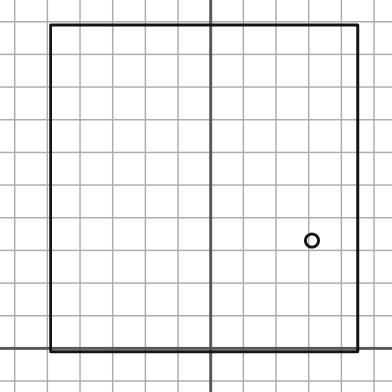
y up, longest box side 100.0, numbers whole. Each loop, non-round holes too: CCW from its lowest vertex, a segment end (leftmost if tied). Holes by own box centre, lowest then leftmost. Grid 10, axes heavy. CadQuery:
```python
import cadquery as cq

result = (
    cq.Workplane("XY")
    .moveTo(-49.0, -1.0)
    .lineTo(45.0, -1.0)
    .lineTo(45.0, 99.0)
    .lineTo(-49.0, 99.0)
    .close()
    .moveTo(31.0, 33.0)
    .circle(2.0)
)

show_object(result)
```